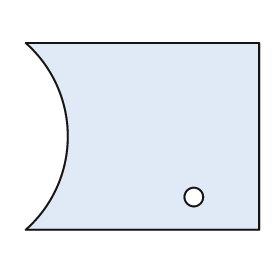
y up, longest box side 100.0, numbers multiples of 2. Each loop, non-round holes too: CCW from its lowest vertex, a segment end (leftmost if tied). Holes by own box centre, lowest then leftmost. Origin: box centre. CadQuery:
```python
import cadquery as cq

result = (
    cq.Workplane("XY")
    .moveTo(-50.0, -40.0)
    .lineTo(50.0, -40.0)
    .lineTo(50.0, 40.0)
    .lineTo(-50.0, 40.0)
    .threePointArc((-32.0, 0.0), (-50.0, -40.0))
    .close()
    .moveTo(22.0, -26.0)
    .circle(4.0)
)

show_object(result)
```